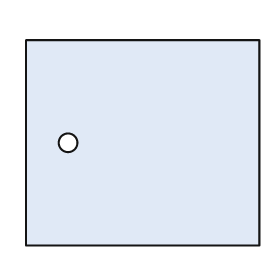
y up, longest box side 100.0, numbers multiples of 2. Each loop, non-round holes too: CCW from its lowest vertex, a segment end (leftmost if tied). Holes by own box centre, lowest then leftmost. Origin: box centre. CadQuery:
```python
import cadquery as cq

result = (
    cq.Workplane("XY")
    .moveTo(-50.0, -44.0)
    .lineTo(50.0, -44.0)
    .lineTo(50.0, 44.0)
    .lineTo(-50.0, 44.0)
    .close()
    .moveTo(-32.0, 0.0)
    .circle(4.0)
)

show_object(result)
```